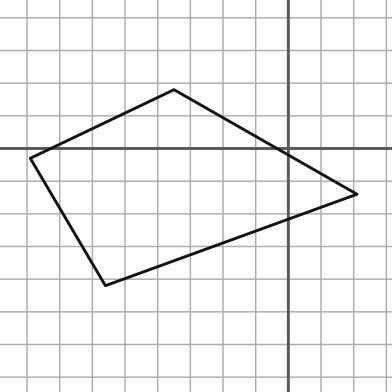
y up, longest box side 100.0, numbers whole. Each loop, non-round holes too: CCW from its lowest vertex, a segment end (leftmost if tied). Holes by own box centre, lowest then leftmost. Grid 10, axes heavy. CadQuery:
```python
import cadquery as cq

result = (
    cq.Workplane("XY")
    .moveTo(-56.0, -42.0)
    .lineTo(21.0, -14.0)
    .lineTo(-35.0, 18.0)
    .lineTo(-79.0, -3.0)
    .close()
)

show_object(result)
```